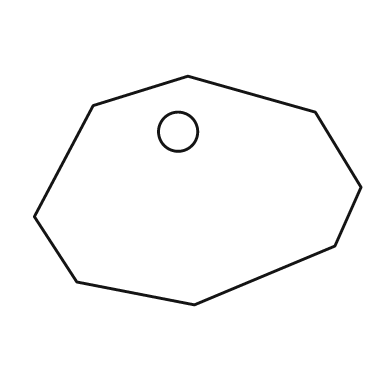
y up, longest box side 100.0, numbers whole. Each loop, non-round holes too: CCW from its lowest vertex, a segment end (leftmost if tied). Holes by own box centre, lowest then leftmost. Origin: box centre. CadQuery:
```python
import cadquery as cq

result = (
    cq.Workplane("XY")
    .moveTo(-1.0, -35.0)
    .lineTo(42.0, -17.0)
    .lineTo(50.0, 1.0)
    .lineTo(36.0, 24.0)
    .lineTo(-3.0, 35.0)
    .lineTo(-32.0, 26.0)
    .lineTo(-50.0, -8.0)
    .lineTo(-37.0, -28.0)
    .close()
    .moveTo(-6.0, 18.0)
    .circle(6.0)
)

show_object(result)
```